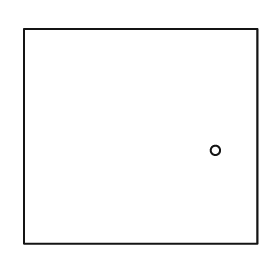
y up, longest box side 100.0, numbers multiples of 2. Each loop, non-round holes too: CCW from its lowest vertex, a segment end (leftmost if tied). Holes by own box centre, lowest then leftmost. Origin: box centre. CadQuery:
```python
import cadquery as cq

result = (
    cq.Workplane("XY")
    .moveTo(-50.0, -46.0)
    .lineTo(50.0, -46.0)
    .lineTo(50.0, 46.0)
    .lineTo(-50.0, 46.0)
    .close()
    .moveTo(32.0, -6.0)
    .circle(2.0)
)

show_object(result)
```